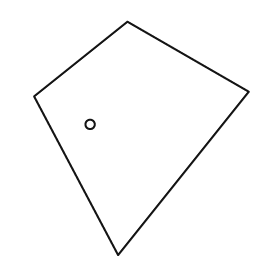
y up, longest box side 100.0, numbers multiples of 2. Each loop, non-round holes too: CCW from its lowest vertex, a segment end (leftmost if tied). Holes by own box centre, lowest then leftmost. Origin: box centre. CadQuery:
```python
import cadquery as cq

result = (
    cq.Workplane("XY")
    .moveTo(-10.0, -50.0)
    .lineTo(46.0, 20.0)
    .lineTo(-6.0, 50.0)
    .lineTo(-46.0, 18.0)
    .close()
    .moveTo(-22.0, 6.0)
    .circle(2.0)
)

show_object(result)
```